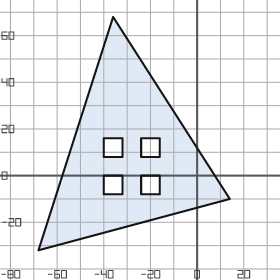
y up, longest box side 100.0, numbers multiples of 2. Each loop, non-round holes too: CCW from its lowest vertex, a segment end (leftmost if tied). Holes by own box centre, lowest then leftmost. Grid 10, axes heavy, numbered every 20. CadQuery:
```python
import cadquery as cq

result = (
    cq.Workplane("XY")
    .moveTo(-68.0, -32.0)
    .lineTo(14.0, -10.0)
    .lineTo(-36.0, 68.0)
    .close()
    .moveTo(-40.0, -8.0)
    .lineTo(-32.0, -8.0)
    .lineTo(-32.0, 0.0)
    .lineTo(-40.0, 0.0)
    .close()
    .moveTo(-24.0, -8.0)
    .lineTo(-16.0, -8.0)
    .lineTo(-16.0, 0.0)
    .lineTo(-24.0, 0.0)
    .close()
    .moveTo(-40.0, 8.0)
    .lineTo(-32.0, 8.0)
    .lineTo(-32.0, 16.0)
    .lineTo(-40.0, 16.0)
    .close()
    .moveTo(-24.0, 8.0)
    .lineTo(-16.0, 8.0)
    .lineTo(-16.0, 16.0)
    .lineTo(-24.0, 16.0)
    .close()
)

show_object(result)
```